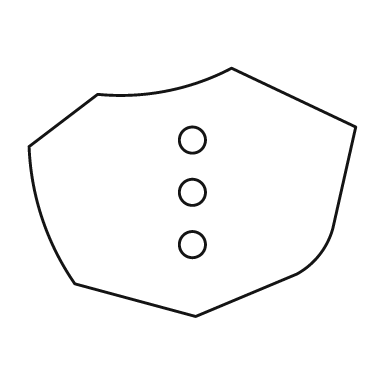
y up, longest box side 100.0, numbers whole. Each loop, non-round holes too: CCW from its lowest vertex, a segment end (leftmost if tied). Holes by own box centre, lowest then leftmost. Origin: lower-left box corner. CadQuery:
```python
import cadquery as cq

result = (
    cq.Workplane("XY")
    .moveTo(51.0, 0.0)
    .lineTo(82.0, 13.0)
    .threePointArc((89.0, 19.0), (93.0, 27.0))
    .lineTo(100.0, 58.0)
    .lineTo(62.0, 76.0)
    .threePointArc((42.0, 69.0), (21.0, 68.0))
    .lineTo(0.0, 52.0)
    .threePointArc((4.0, 30.0), (14.0, 10.0))
    .close()
    .moveTo(50.0, 22.0)
    .circle(4.0)
    .moveTo(50.0, 38.0)
    .circle(4.0)
    .moveTo(50.0, 54.0)
    .circle(4.0)
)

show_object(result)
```